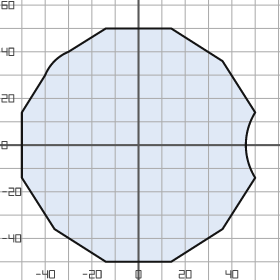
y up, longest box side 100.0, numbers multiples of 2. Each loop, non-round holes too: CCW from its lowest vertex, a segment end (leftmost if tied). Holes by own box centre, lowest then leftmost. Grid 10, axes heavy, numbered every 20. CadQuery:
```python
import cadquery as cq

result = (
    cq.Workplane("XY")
    .moveTo(-14.0, -50.0)
    .lineTo(14.0, -50.0)
    .lineTo(36.0, -36.0)
    .lineTo(50.0, -14.0)
    .threePointArc((46.0, 0.0), (50.0, 14.0))
    .lineTo(36.0, 36.0)
    .lineTo(14.0, 50.0)
    .lineTo(-14.0, 50.0)
    .lineTo(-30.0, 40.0)
    .threePointArc((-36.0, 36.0), (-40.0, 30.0))
    .lineTo(-50.0, 14.0)
    .lineTo(-50.0, -14.0)
    .lineTo(-36.0, -36.0)
    .close()
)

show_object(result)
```